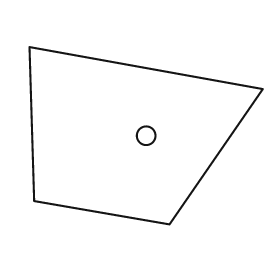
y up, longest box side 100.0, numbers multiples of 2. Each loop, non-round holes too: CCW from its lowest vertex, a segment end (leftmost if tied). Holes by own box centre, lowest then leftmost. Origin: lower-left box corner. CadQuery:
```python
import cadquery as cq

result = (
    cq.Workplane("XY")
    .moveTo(60.0, 0.0)
    .lineTo(100.0, 58.0)
    .lineTo(0.0, 76.0)
    .lineTo(2.0, 10.0)
    .close()
    .moveTo(50.0, 38.0)
    .circle(4.0)
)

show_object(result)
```